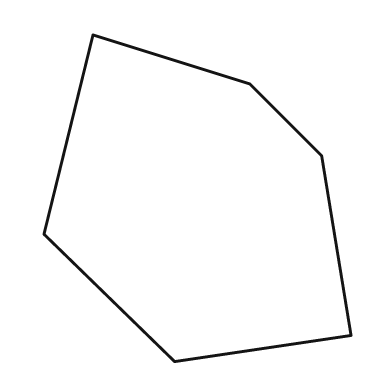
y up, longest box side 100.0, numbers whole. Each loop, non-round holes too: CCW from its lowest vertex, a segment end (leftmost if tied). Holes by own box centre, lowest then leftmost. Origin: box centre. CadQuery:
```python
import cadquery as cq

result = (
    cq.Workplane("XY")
    .moveTo(-7.0, -50.0)
    .lineTo(47.0, -42.0)
    .lineTo(38.0, 13.0)
    .lineTo(16.0, 35.0)
    .lineTo(-32.0, 50.0)
    .lineTo(-47.0, -11.0)
    .close()
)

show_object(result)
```